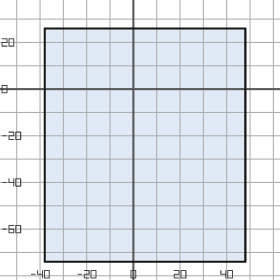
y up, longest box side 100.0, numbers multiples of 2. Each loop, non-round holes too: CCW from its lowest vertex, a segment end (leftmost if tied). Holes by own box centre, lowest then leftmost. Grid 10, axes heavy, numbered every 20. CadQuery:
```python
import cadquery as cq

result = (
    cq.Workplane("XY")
    .moveTo(-38.0, -74.0)
    .lineTo(48.0, -74.0)
    .lineTo(48.0, 26.0)
    .lineTo(-38.0, 26.0)
    .close()
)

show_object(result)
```